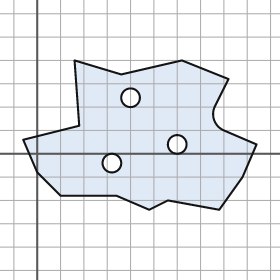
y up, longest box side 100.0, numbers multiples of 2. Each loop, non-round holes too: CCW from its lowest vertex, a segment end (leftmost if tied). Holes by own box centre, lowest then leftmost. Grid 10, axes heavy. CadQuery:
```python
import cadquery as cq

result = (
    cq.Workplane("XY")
    .moveTo(48.0, -24.0)
    .lineTo(56.0, -20.0)
    .lineTo(78.0, -24.0)
    .lineTo(88.0, -10.0)
    .lineTo(94.0, 4.0)
    .lineTo(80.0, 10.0)
    .threePointArc((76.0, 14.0), (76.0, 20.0))
    .lineTo(82.0, 32.0)
    .lineTo(62.0, 40.0)
    .lineTo(36.0, 34.0)
    .lineTo(16.0, 40.0)
    .lineTo(18.0, 12.0)
    .lineTo(-6.0, 6.0)
    .lineTo(0.0, -8.0)
    .lineTo(10.0, -18.0)
    .lineTo(34.0, -18.0)
    .close()
    .moveTo(32.0, -4.0)
    .circle(4.0)
    .moveTo(60.0, 4.0)
    .circle(4.0)
    .moveTo(40.0, 24.0)
    .circle(4.0)
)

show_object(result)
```